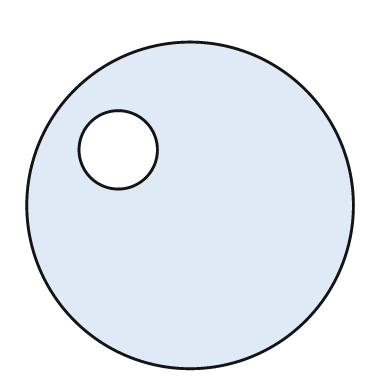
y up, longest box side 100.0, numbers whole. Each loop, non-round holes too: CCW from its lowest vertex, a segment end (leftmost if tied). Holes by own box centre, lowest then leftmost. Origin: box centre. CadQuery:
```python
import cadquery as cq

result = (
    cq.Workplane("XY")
    .moveTo(0.0, 0.0)
    .circle(50.0)
    .moveTo(-22.0, 17.0)
    .circle(12.0)
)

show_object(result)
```